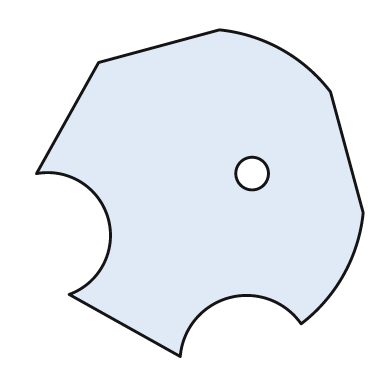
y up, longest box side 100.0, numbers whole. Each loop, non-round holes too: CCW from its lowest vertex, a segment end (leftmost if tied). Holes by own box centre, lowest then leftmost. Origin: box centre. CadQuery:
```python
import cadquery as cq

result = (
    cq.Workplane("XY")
    .moveTo(-6.0, -50.0)
    .threePointArc((9.0, -32.0), (31.0, -40.0))
    .threePointArc((44.0, -25.0), (50.0, -6.0))
    .lineTo(40.0, 31.0)
    .threePointArc((25.0, 44.0), (6.0, 50.0))
    .lineTo(-31.0, 40.0)
    .lineTo(-50.0, 6.0)
    .threePointArc((-28.0, -8.0), (-40.0, -31.0))
    .close()
    .moveTo(16.0, 6.0)
    .circle(5.0)
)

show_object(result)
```